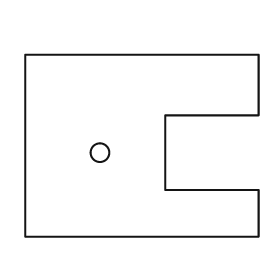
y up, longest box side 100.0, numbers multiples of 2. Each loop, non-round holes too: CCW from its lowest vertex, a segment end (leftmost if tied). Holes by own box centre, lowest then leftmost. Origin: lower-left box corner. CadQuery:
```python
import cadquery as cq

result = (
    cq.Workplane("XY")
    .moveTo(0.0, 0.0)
    .lineTo(100.0, 0.0)
    .lineTo(100.0, 20.0)
    .lineTo(60.0, 20.0)
    .lineTo(60.0, 52.0)
    .lineTo(100.0, 52.0)
    .lineTo(100.0, 78.0)
    .lineTo(0.0, 78.0)
    .close()
    .moveTo(32.0, 36.0)
    .circle(4.0)
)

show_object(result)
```